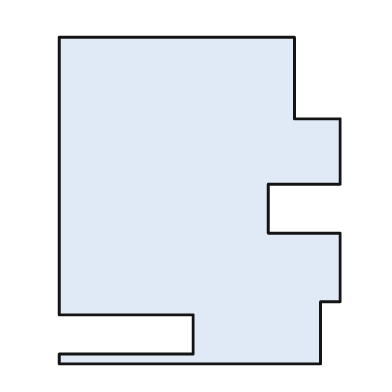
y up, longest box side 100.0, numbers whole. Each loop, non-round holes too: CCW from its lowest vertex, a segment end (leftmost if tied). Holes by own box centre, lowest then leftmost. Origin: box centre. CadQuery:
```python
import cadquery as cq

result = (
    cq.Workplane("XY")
    .moveTo(-43.0, -50.0)
    .lineTo(37.0, -50.0)
    .lineTo(37.0, -31.0)
    .lineTo(43.0, -31.0)
    .lineTo(43.0, -10.0)
    .lineTo(21.0, -10.0)
    .lineTo(21.0, 5.0)
    .lineTo(43.0, 5.0)
    .lineTo(43.0, 25.0)
    .lineTo(29.0, 25.0)
    .lineTo(29.0, 50.0)
    .lineTo(-43.0, 50.0)
    .lineTo(-43.0, -35.0)
    .lineTo(-2.0, -35.0)
    .lineTo(-2.0, -47.0)
    .lineTo(-43.0, -47.0)
    .close()
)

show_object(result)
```